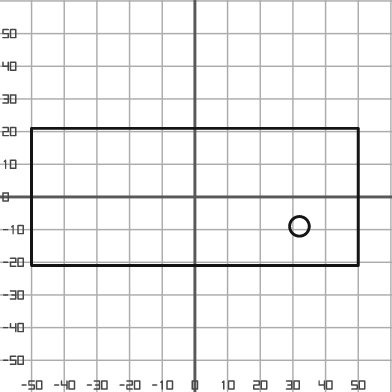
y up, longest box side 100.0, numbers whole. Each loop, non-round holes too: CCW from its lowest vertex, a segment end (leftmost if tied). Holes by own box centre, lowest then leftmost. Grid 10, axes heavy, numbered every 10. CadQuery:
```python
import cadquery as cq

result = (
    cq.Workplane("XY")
    .moveTo(-50.0, -21.0)
    .lineTo(50.0, -21.0)
    .lineTo(50.0, 21.0)
    .lineTo(-50.0, 21.0)
    .close()
    .moveTo(32.0, -9.0)
    .circle(3.0)
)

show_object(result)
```